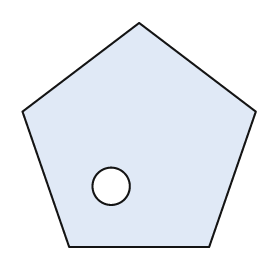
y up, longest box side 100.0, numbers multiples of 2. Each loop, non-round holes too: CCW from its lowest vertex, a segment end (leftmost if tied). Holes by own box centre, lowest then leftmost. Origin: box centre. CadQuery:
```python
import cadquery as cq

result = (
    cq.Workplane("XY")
    .moveTo(-30.0, -48.0)
    .lineTo(30.0, -48.0)
    .lineTo(50.0, 10.0)
    .lineTo(0.0, 48.0)
    .lineTo(-50.0, 10.0)
    .close()
    .moveTo(-12.0, -22.0)
    .circle(8.0)
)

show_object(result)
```